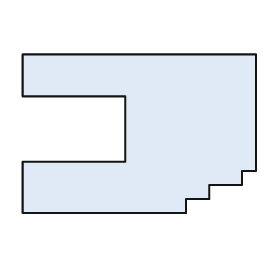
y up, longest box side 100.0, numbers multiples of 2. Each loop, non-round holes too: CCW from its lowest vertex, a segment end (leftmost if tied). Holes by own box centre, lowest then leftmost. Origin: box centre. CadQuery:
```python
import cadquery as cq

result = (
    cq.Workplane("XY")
    .moveTo(-50.0, -34.0)
    .lineTo(20.0, -34.0)
    .lineTo(20.0, -28.0)
    .lineTo(30.0, -28.0)
    .lineTo(30.0, -22.0)
    .lineTo(44.0, -22.0)
    .lineTo(44.0, -16.0)
    .lineTo(50.0, -16.0)
    .lineTo(50.0, 34.0)
    .lineTo(-50.0, 34.0)
    .lineTo(-50.0, 16.0)
    .lineTo(-6.0, 16.0)
    .lineTo(-6.0, -12.0)
    .lineTo(-50.0, -12.0)
    .close()
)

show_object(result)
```